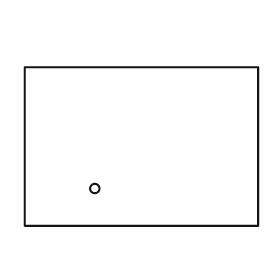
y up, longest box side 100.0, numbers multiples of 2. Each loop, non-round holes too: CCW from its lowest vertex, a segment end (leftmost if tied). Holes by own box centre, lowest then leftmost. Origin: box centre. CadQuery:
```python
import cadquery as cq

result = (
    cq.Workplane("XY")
    .moveTo(-50.0, -34.0)
    .lineTo(50.0, -34.0)
    .lineTo(50.0, 34.0)
    .lineTo(-50.0, 34.0)
    .close()
    .moveTo(-20.0, -18.0)
    .circle(2.0)
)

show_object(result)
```